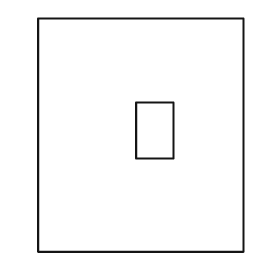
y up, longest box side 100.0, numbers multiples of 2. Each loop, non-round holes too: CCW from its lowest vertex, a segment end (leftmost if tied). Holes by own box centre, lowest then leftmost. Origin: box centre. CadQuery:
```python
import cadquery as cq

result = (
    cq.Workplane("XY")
    .moveTo(-44.0, -50.0)
    .lineTo(44.0, -50.0)
    .lineTo(44.0, 50.0)
    .lineTo(-44.0, 50.0)
    .close()
    .moveTo(-2.0, -10.0)
    .lineTo(14.0, -10.0)
    .lineTo(14.0, 14.0)
    .lineTo(-2.0, 14.0)
    .close()
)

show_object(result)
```